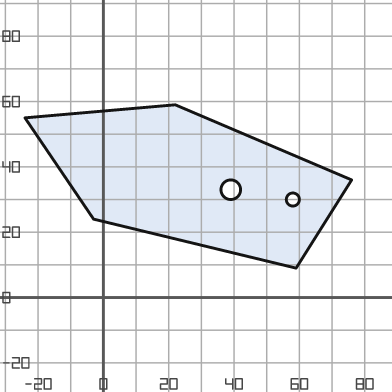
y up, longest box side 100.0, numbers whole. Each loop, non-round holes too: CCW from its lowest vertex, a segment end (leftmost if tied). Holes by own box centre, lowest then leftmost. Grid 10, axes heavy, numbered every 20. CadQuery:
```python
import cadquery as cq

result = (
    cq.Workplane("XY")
    .moveTo(59.0, 9.0)
    .lineTo(76.0, 36.0)
    .lineTo(22.0, 59.0)
    .lineTo(-24.0, 55.0)
    .lineTo(-3.0, 24.0)
    .close()
    .moveTo(58.0, 30.0)
    .circle(2.0)
    .moveTo(39.0, 33.0)
    .circle(3.0)
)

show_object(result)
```